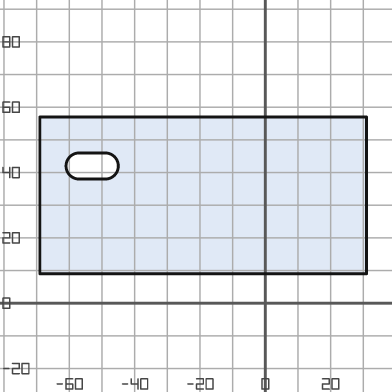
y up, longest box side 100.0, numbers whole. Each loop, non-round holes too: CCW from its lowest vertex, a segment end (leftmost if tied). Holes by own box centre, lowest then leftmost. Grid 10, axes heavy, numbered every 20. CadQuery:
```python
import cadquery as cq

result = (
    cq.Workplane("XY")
    .moveTo(-69.0, 9.0)
    .lineTo(31.0, 9.0)
    .lineTo(31.0, 57.0)
    .lineTo(-69.0, 57.0)
    .close()
    .moveTo(-57.0, 38.0)
    .lineTo(-49.0, 38.0)
    .threePointArc((-45.0, 42.0), (-49.0, 46.0))
    .lineTo(-57.0, 46.0)
    .threePointArc((-61.0, 42.0), (-57.0, 38.0))
    .close()
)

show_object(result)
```